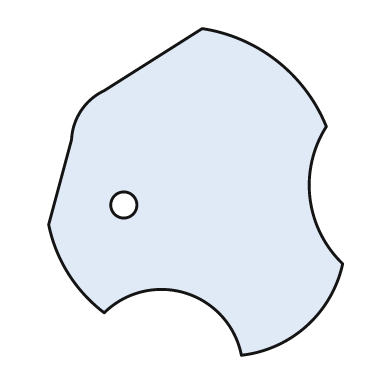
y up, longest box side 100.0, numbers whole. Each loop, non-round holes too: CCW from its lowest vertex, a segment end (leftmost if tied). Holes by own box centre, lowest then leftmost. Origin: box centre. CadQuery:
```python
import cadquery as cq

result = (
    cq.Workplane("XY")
    .moveTo(14.0, -50.0)
    .threePointArc((34.0, -41.0), (45.0, -22.0))
    .threePointArc((35.0, -2.0), (40.0, 20.0))
    .threePointArc((25.0, 40.0), (2.0, 50.0))
    .lineTo(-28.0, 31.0)
    .threePointArc((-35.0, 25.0), (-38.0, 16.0))
    .lineTo(-45.0, -10.0)
    .threePointArc((-39.0, -25.0), (-28.0, -37.0))
    .threePointArc((-3.0, -31.0), (14.0, -50.0))
    .close()
    .moveTo(-22.0, -4.0)
    .circle(4.0)
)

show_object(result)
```